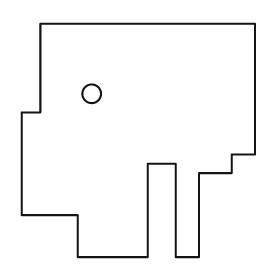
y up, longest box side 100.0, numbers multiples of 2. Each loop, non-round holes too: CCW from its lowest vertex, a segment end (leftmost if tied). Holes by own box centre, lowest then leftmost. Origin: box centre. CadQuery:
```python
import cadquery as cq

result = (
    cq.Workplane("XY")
    .moveTo(-26.0, -50.0)
    .lineTo(4.0, -50.0)
    .lineTo(4.0, -10.0)
    .lineTo(16.0, -10.0)
    .lineTo(16.0, -50.0)
    .lineTo(26.0, -50.0)
    .lineTo(26.0, -14.0)
    .lineTo(40.0, -14.0)
    .lineTo(40.0, -6.0)
    .lineTo(50.0, -6.0)
    .lineTo(50.0, 50.0)
    .lineTo(-42.0, 50.0)
    .lineTo(-42.0, 12.0)
    .lineTo(-50.0, 12.0)
    .lineTo(-50.0, -32.0)
    .lineTo(-26.0, -32.0)
    .close()
    .moveTo(-20.0, 20.0)
    .circle(4.0)
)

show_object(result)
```